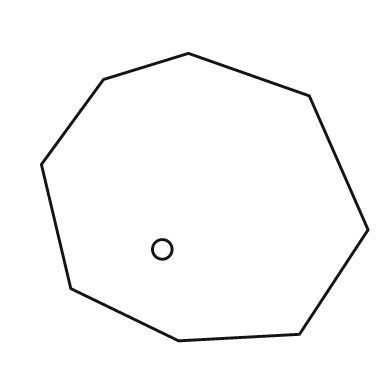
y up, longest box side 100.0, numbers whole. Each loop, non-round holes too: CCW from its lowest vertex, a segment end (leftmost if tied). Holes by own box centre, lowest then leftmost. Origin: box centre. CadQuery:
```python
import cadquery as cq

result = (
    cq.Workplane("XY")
    .moveTo(-8.0, -44.0)
    .lineTo(29.0, -42.0)
    .lineTo(50.0, -10.0)
    .lineTo(32.0, 31.0)
    .lineTo(-5.0, 44.0)
    .lineTo(-31.0, 36.0)
    .lineTo(-50.0, 10.0)
    .lineTo(-41.0, -28.0)
    .close()
    .moveTo(-13.0, -16.0)
    .circle(3.0)
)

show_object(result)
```